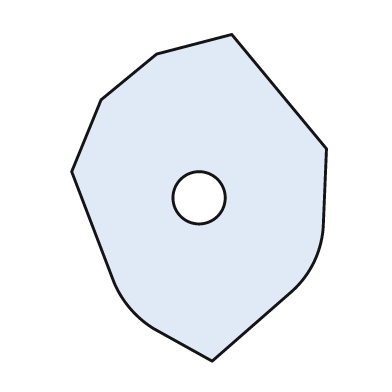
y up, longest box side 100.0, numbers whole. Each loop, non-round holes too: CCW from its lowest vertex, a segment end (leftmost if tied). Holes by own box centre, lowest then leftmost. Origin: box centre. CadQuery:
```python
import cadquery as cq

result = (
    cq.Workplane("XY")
    .moveTo(4.0, -50.0)
    .lineTo(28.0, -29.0)
    .threePointArc((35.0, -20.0), (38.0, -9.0))
    .lineTo(39.0, 15.0)
    .lineTo(10.0, 50.0)
    .lineTo(-13.0, 44.0)
    .lineTo(-30.0, 30.0)
    .lineTo(-39.0, 8.0)
    .lineTo(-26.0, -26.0)
    .threePointArc((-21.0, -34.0), (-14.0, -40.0))
    .close()
    .moveTo(0.0, 0.0)
    .circle(8.0)
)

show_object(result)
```